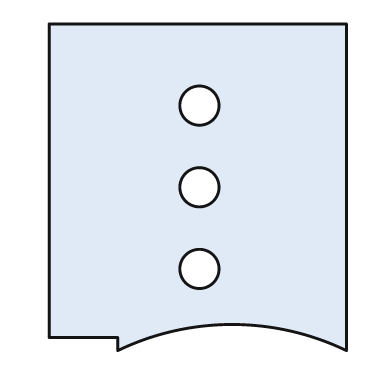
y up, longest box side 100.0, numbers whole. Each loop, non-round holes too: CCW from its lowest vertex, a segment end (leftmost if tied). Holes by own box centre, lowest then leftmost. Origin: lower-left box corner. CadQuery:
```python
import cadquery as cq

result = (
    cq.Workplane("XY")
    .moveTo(21.0, 0.0)
    .threePointArc((56.0, 8.0), (91.0, 0.0))
    .lineTo(91.0, 100.0)
    .lineTo(0.0, 100.0)
    .lineTo(0.0, 4.0)
    .lineTo(21.0, 4.0)
    .close()
    .moveTo(46.0, 25.0)
    .circle(6.0)
    .moveTo(46.0, 50.0)
    .circle(6.0)
    .moveTo(46.0, 75.0)
    .circle(6.0)
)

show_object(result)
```